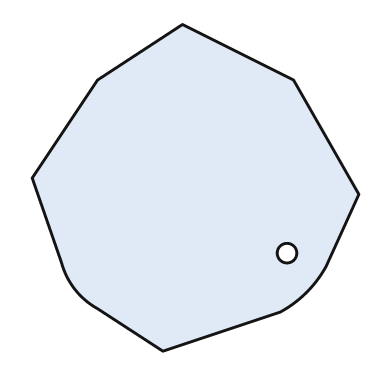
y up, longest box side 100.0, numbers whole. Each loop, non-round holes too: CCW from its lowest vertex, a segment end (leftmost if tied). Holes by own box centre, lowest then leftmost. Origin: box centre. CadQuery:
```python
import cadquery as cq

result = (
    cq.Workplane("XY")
    .moveTo(-10.0, -50.0)
    .lineTo(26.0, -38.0)
    .threePointArc((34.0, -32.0), (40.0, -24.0))
    .lineTo(50.0, -2.0)
    .lineTo(30.0, 33.0)
    .lineTo(-4.0, 50.0)
    .lineTo(-30.0, 33.0)
    .lineTo(-50.0, 3.0)
    .lineTo(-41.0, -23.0)
    .threePointArc((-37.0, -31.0), (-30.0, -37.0))
    .close()
    .moveTo(28.0, -20.0)
    .circle(3.0)
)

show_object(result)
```